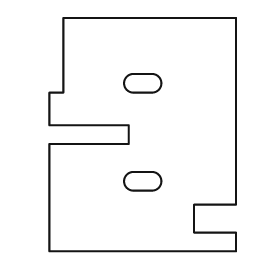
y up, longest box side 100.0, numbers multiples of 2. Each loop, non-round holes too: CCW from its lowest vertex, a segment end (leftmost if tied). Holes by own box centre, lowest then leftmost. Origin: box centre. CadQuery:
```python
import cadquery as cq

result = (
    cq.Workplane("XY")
    .moveTo(-40.0, -50.0)
    .lineTo(40.0, -50.0)
    .lineTo(40.0, -42.0)
    .lineTo(22.0, -42.0)
    .lineTo(22.0, -30.0)
    .lineTo(40.0, -30.0)
    .lineTo(40.0, 50.0)
    .lineTo(-34.0, 50.0)
    .lineTo(-34.0, 18.0)
    .lineTo(-40.0, 18.0)
    .lineTo(-40.0, 4.0)
    .lineTo(-6.0, 4.0)
    .lineTo(-6.0, -4.0)
    .lineTo(-40.0, -4.0)
    .close()
    .moveTo(-4.0, -24.0)
    .lineTo(4.0, -24.0)
    .threePointArc((8.0, -20.0), (4.0, -16.0))
    .lineTo(-4.0, -16.0)
    .threePointArc((-8.0, -20.0), (-4.0, -24.0))
    .close()
    .moveTo(-4.0, 18.0)
    .lineTo(4.0, 18.0)
    .threePointArc((8.0, 22.0), (4.0, 26.0))
    .lineTo(-4.0, 26.0)
    .threePointArc((-8.0, 22.0), (-4.0, 18.0))
    .close()
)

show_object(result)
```